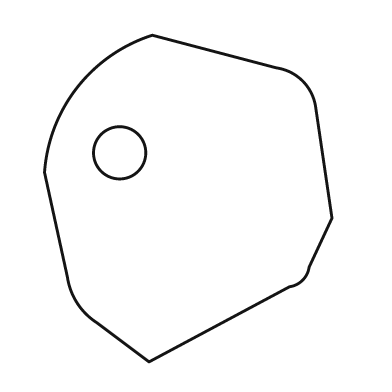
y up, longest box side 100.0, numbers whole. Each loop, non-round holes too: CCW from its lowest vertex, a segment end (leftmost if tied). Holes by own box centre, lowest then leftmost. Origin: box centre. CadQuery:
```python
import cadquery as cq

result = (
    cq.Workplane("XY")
    .moveTo(-12.0, -50.0)
    .lineTo(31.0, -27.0)
    .threePointArc((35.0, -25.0), (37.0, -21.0))
    .lineTo(44.0, -6.0)
    .lineTo(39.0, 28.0)
    .threePointArc((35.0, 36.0), (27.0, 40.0))
    .lineTo(-11.0, 50.0)
    .threePointArc((-34.0, 34.0), (-44.0, 8.0))
    .lineTo(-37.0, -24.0)
    .threePointArc((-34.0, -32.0), (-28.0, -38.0))
    .close()
    .moveTo(-21.0, 14.0)
    .circle(8.0)
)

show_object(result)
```